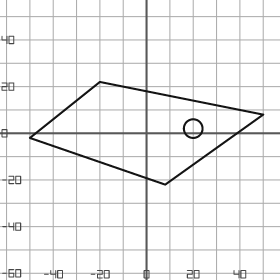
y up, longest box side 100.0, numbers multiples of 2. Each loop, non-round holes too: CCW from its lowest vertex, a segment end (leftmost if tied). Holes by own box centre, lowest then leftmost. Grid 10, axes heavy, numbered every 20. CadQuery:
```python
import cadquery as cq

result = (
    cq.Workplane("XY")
    .moveTo(8.0, -22.0)
    .lineTo(50.0, 8.0)
    .lineTo(-20.0, 22.0)
    .lineTo(-50.0, -2.0)
    .close()
    .moveTo(20.0, 2.0)
    .circle(4.0)
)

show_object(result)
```